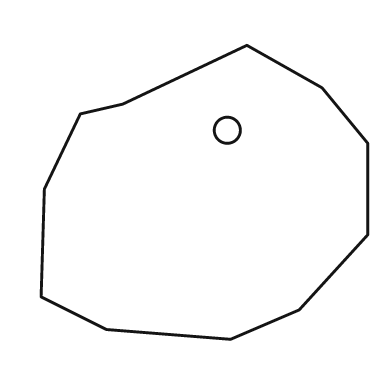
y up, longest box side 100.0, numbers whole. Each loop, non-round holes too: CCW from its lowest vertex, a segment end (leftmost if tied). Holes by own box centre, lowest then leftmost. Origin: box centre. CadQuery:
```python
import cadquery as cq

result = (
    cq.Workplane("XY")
    .moveTo(8.0, -45.0)
    .lineTo(29.0, -36.0)
    .lineTo(50.0, -13.0)
    .lineTo(50.0, 15.0)
    .lineTo(36.0, 32.0)
    .lineTo(13.0, 45.0)
    .lineTo(-25.0, 27.0)
    .lineTo(-38.0, 24.0)
    .lineTo(-49.0, 1.0)
    .lineTo(-50.0, -32.0)
    .lineTo(-30.0, -42.0)
    .close()
    .moveTo(7.0, 19.0)
    .circle(4.0)
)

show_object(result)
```